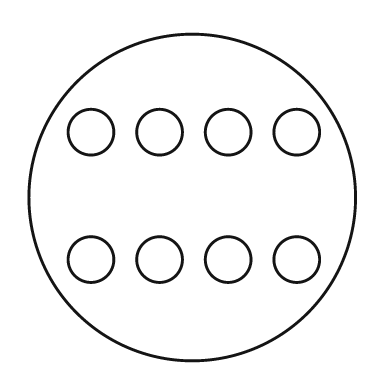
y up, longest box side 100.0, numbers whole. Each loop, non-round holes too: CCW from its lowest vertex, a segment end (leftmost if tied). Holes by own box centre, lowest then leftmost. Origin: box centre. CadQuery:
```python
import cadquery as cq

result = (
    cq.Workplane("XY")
    .moveTo(0.0, 0.0)
    .circle(50.0)
    .moveTo(-31.0, -19.0)
    .circle(7.0)
    .moveTo(-10.0, -19.0)
    .circle(7.0)
    .moveTo(11.0, -19.0)
    .circle(7.0)
    .moveTo(32.0, -19.0)
    .circle(7.0)
    .moveTo(-31.0, 20.0)
    .circle(7.0)
    .moveTo(-10.0, 20.0)
    .circle(7.0)
    .moveTo(11.0, 20.0)
    .circle(7.0)
    .moveTo(32.0, 20.0)
    .circle(7.0)
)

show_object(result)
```